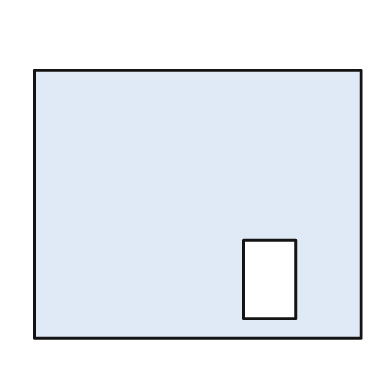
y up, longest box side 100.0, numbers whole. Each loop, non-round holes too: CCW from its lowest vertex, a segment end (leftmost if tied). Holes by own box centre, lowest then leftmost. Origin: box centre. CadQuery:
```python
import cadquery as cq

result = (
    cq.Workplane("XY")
    .moveTo(-50.0, -41.0)
    .lineTo(50.0, -41.0)
    .lineTo(50.0, 41.0)
    .lineTo(-50.0, 41.0)
    .close()
    .moveTo(14.0, -35.0)
    .lineTo(30.0, -35.0)
    .lineTo(30.0, -11.0)
    .lineTo(14.0, -11.0)
    .close()
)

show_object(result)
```